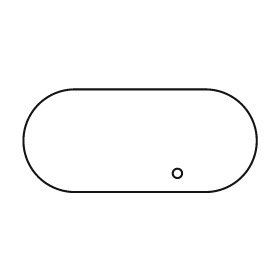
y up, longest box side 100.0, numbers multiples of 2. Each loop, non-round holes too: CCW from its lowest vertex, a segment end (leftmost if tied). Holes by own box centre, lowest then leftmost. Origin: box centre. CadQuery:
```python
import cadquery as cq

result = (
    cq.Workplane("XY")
    .moveTo(-28.0, -22.0)
    .lineTo(28.0, -22.0)
    .threePointArc((50.0, 0.0), (28.0, 22.0))
    .lineTo(-28.0, 22.0)
    .threePointArc((-50.0, 0.0), (-28.0, -22.0))
    .close()
    .moveTo(16.0, -14.0)
    .circle(2.0)
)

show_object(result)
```